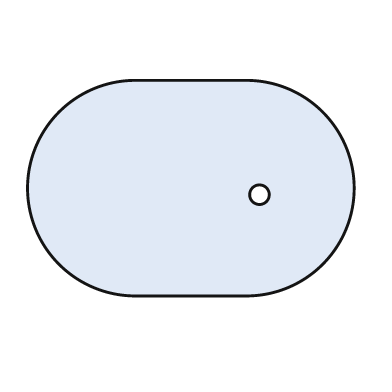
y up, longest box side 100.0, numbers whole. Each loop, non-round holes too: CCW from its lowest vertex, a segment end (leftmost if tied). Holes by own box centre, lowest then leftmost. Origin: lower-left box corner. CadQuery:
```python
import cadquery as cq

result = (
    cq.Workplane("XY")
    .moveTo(33.0, 0.0)
    .lineTo(67.0, 0.0)
    .threePointArc((100.0, 33.0), (67.0, 66.0))
    .lineTo(33.0, 66.0)
    .threePointArc((0.0, 33.0), (33.0, 0.0))
    .close()
    .moveTo(71.0, 31.0)
    .circle(3.0)
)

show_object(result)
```